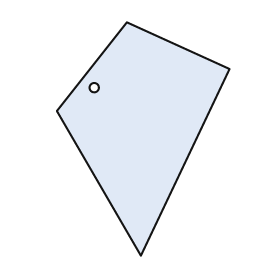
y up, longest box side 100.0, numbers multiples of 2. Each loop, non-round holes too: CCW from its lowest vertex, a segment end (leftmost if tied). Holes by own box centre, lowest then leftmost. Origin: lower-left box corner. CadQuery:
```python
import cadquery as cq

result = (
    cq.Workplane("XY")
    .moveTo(36.0, 0.0)
    .lineTo(74.0, 80.0)
    .lineTo(30.0, 100.0)
    .lineTo(0.0, 62.0)
    .close()
    .moveTo(16.0, 72.0)
    .circle(2.0)
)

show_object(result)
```